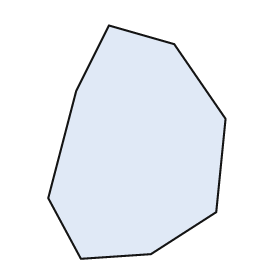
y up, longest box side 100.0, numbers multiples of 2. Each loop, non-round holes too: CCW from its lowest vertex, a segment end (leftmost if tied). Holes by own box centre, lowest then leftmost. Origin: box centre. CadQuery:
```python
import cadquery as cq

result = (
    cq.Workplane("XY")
    .moveTo(-24.0, -50.0)
    .lineTo(6.0, -48.0)
    .lineTo(34.0, -30.0)
    .lineTo(38.0, 10.0)
    .lineTo(16.0, 42.0)
    .lineTo(-12.0, 50.0)
    .lineTo(-26.0, 22.0)
    .lineTo(-38.0, -24.0)
    .close()
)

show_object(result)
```